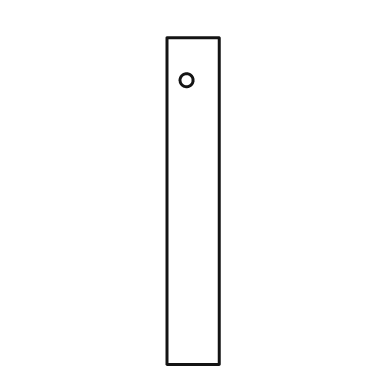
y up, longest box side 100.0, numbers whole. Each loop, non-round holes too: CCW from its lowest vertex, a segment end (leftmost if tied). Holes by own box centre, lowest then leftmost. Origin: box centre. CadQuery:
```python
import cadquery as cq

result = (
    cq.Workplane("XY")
    .moveTo(-8.0, -50.0)
    .lineTo(8.0, -50.0)
    .lineTo(8.0, 50.0)
    .lineTo(-8.0, 50.0)
    .close()
    .moveTo(-2.0, 37.0)
    .circle(2.0)
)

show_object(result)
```